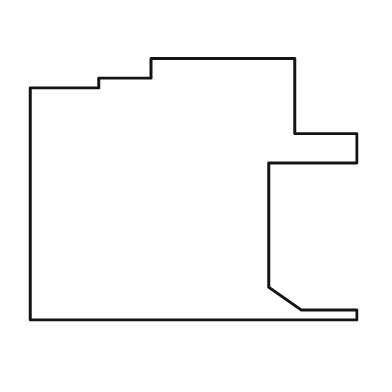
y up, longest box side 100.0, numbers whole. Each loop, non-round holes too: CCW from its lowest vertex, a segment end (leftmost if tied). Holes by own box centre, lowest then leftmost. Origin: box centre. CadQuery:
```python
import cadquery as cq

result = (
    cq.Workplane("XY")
    .moveTo(-50.0, -40.0)
    .lineTo(50.0, -40.0)
    .lineTo(50.0, -37.0)
    .lineTo(33.0, -37.0)
    .lineTo(23.0, -30.0)
    .lineTo(23.0, 8.0)
    .lineTo(50.0, 8.0)
    .lineTo(50.0, 17.0)
    .lineTo(31.0, 17.0)
    .lineTo(31.0, 40.0)
    .lineTo(-13.0, 40.0)
    .lineTo(-13.0, 34.0)
    .lineTo(-29.0, 34.0)
    .lineTo(-29.0, 31.0)
    .lineTo(-50.0, 31.0)
    .close()
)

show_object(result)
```